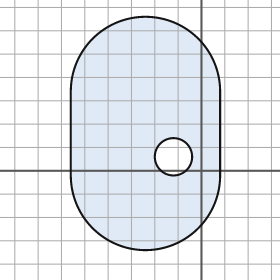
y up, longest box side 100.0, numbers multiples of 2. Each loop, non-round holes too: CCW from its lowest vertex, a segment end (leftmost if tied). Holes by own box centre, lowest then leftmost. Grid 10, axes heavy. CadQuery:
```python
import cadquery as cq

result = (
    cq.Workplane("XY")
    .moveTo(-56.0, -2.0)
    .threePointArc((-24.0, -34.0), (8.0, -2.0))
    .lineTo(8.0, 34.0)
    .threePointArc((-24.0, 66.0), (-56.0, 34.0))
    .close()
    .moveTo(-12.0, 6.0)
    .circle(8.0)
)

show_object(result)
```